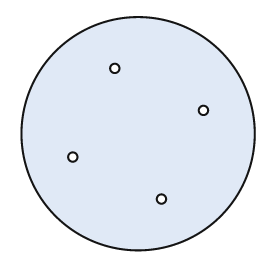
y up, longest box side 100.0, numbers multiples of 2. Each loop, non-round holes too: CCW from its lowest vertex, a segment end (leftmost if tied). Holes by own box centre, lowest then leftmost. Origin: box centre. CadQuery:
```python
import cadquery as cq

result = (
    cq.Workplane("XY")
    .moveTo(0.0, 0.0)
    .circle(50.0)
    .moveTo(10.0, -28.0)
    .circle(2.0)
    .moveTo(-28.0, -10.0)
    .circle(2.0)
    .moveTo(28.0, 10.0)
    .circle(2.0)
    .moveTo(-10.0, 28.0)
    .circle(2.0)
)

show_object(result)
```